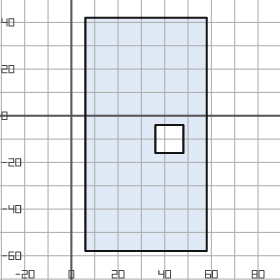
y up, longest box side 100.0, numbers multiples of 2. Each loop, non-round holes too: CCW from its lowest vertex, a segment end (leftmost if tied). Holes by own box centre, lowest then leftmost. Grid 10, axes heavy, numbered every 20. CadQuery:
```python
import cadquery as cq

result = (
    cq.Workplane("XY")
    .moveTo(6.0, -58.0)
    .lineTo(58.0, -58.0)
    .lineTo(58.0, 42.0)
    .lineTo(6.0, 42.0)
    .close()
    .moveTo(36.0, -16.0)
    .lineTo(48.0, -16.0)
    .lineTo(48.0, -4.0)
    .lineTo(36.0, -4.0)
    .close()
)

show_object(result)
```